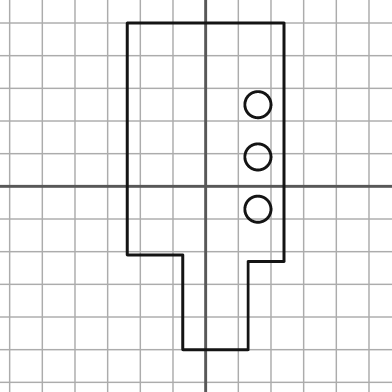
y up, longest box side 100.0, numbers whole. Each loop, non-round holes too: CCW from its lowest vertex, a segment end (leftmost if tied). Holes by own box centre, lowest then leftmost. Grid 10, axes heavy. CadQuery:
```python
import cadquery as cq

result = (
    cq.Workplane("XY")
    .moveTo(-7.0, -50.0)
    .lineTo(13.0, -50.0)
    .lineTo(13.0, -23.0)
    .lineTo(24.0, -23.0)
    .lineTo(24.0, 50.0)
    .lineTo(-24.0, 50.0)
    .lineTo(-24.0, -21.0)
    .lineTo(-7.0, -21.0)
    .close()
    .moveTo(16.0, -7.0)
    .circle(4.0)
    .moveTo(16.0, 9.0)
    .circle(4.0)
    .moveTo(16.0, 25.0)
    .circle(4.0)
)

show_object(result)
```